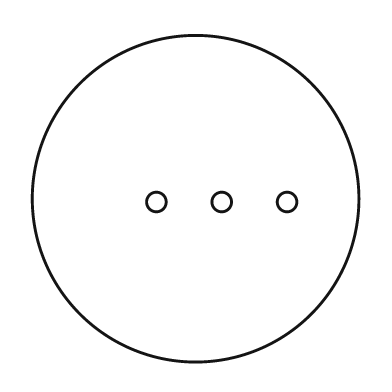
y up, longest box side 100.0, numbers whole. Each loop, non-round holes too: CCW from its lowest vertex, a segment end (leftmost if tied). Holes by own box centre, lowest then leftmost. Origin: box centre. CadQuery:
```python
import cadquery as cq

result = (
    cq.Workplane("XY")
    .moveTo(0.0, 0.0)
    .circle(50.0)
    .moveTo(-12.0, -1.0)
    .circle(3.0)
    .moveTo(8.0, -1.0)
    .circle(3.0)
    .moveTo(28.0, -1.0)
    .circle(3.0)
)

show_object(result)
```